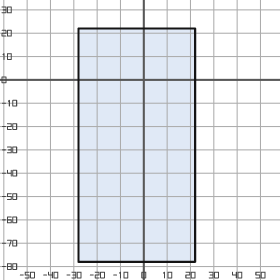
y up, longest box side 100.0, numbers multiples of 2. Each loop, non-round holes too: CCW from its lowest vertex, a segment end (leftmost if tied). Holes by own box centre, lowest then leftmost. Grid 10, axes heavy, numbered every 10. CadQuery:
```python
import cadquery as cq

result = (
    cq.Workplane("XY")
    .moveTo(-28.0, -78.0)
    .lineTo(22.0, -78.0)
    .lineTo(22.0, 22.0)
    .lineTo(-28.0, 22.0)
    .close()
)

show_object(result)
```